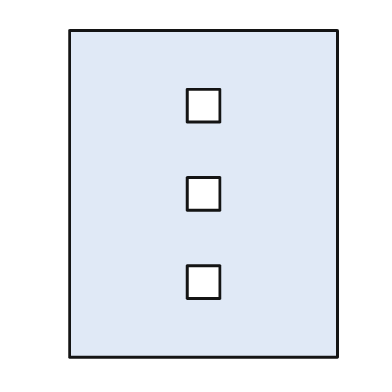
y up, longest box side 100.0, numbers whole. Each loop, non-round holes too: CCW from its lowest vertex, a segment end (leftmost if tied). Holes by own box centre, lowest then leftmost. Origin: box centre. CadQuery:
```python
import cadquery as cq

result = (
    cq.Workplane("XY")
    .moveTo(-41.0, -50.0)
    .lineTo(41.0, -50.0)
    .lineTo(41.0, 50.0)
    .lineTo(-41.0, 50.0)
    .close()
    .moveTo(-5.0, -32.0)
    .lineTo(5.0, -32.0)
    .lineTo(5.0, -22.0)
    .lineTo(-5.0, -22.0)
    .close()
    .moveTo(-5.0, -5.0)
    .lineTo(5.0, -5.0)
    .lineTo(5.0, 5.0)
    .lineTo(-5.0, 5.0)
    .close()
    .moveTo(-5.0, 22.0)
    .lineTo(5.0, 22.0)
    .lineTo(5.0, 32.0)
    .lineTo(-5.0, 32.0)
    .close()
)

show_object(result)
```